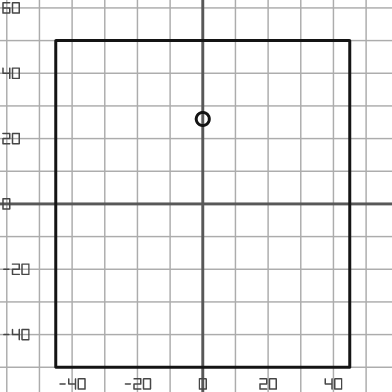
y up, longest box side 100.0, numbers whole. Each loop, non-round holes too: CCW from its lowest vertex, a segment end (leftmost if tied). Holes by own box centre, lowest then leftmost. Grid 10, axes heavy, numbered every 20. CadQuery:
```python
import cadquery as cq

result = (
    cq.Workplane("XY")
    .moveTo(-45.0, -50.0)
    .lineTo(45.0, -50.0)
    .lineTo(45.0, 50.0)
    .lineTo(-45.0, 50.0)
    .close()
    .moveTo(0.0, 26.0)
    .circle(2.0)
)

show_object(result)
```